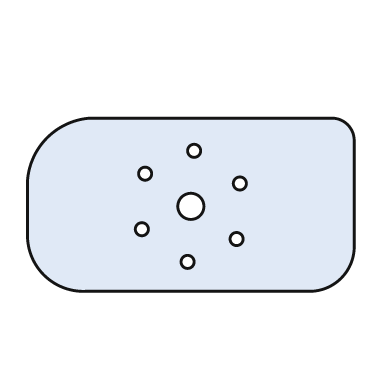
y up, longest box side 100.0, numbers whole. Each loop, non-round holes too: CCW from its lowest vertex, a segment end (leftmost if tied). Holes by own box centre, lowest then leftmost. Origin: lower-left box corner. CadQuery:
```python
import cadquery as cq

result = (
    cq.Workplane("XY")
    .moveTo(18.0, 0.0)
    .lineTo(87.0, 0.0)
    .threePointArc((96.0, 4.0), (100.0, 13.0))
    .lineTo(100.0, 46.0)
    .threePointArc((98.0, 51.0), (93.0, 53.0))
    .lineTo(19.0, 53.0)
    .threePointArc((6.0, 47.0), (0.0, 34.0))
    .lineTo(0.0, 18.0)
    .threePointArc((5.0, 5.0), (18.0, 0.0))
    .close()
    .moveTo(49.0, 9.0)
    .circle(2.0)
    .moveTo(64.0, 16.0)
    .circle(2.0)
    .moveTo(35.0, 19.0)
    .circle(2.0)
    .moveTo(50.0, 26.0)
    .circle(4.0)
    .moveTo(65.0, 33.0)
    .circle(2.0)
    .moveTo(36.0, 36.0)
    .circle(2.0)
    .moveTo(51.0, 43.0)
    .circle(2.0)
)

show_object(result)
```